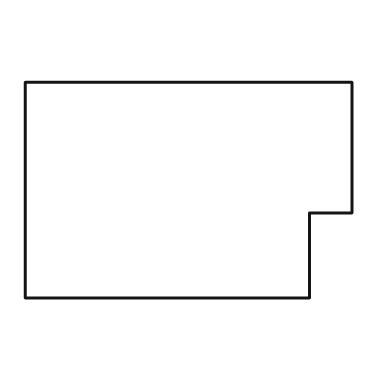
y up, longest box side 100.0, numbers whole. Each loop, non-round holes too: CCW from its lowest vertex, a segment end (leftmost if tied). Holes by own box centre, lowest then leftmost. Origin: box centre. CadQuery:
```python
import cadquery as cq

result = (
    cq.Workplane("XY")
    .moveTo(-50.0, -33.0)
    .lineTo(37.0, -33.0)
    .lineTo(37.0, -7.0)
    .lineTo(50.0, -7.0)
    .lineTo(50.0, 33.0)
    .lineTo(-50.0, 33.0)
    .close()
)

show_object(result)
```